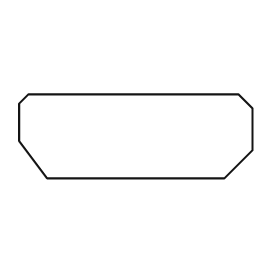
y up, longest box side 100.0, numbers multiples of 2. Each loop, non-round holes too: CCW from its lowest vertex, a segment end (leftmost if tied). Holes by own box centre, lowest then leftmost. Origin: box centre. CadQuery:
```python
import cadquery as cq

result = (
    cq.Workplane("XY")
    .moveTo(-38.0, -18.0)
    .lineTo(38.0, -18.0)
    .lineTo(50.0, -6.0)
    .lineTo(50.0, 12.0)
    .lineTo(44.0, 18.0)
    .lineTo(-46.0, 18.0)
    .lineTo(-50.0, 14.0)
    .lineTo(-50.0, -2.0)
    .close()
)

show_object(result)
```